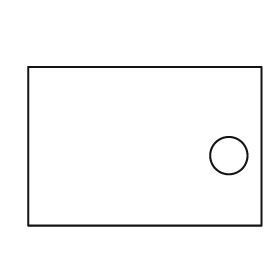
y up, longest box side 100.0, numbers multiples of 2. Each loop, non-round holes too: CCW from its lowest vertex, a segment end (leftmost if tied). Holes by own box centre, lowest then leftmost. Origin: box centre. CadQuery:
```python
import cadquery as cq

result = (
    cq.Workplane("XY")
    .moveTo(-50.0, -34.0)
    .lineTo(50.0, -34.0)
    .lineTo(50.0, 34.0)
    .lineTo(-50.0, 34.0)
    .close()
    .moveTo(36.0, -4.0)
    .circle(8.0)
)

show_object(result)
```